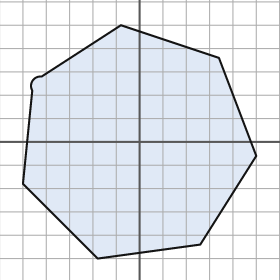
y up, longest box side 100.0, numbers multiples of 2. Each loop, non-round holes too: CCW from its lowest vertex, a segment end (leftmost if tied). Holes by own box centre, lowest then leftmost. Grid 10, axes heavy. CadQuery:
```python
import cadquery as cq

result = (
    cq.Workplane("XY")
    .moveTo(-18.0, -50.0)
    .lineTo(26.0, -44.0)
    .lineTo(50.0, -6.0)
    .lineTo(34.0, 36.0)
    .lineTo(-8.0, 50.0)
    .lineTo(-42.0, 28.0)
    .threePointArc((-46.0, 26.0), (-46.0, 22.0))
    .lineTo(-50.0, -18.0)
    .close()
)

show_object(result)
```